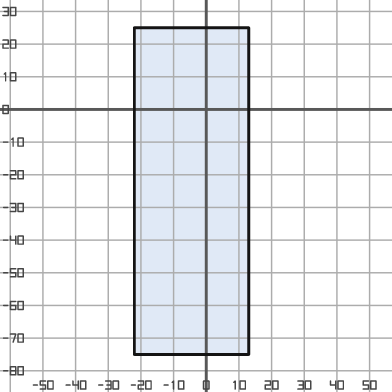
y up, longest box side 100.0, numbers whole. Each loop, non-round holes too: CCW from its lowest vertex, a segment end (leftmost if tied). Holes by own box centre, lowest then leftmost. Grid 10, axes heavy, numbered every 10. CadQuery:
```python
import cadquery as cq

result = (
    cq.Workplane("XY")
    .moveTo(-22.0, -75.0)
    .lineTo(13.0, -75.0)
    .lineTo(13.0, 25.0)
    .lineTo(-22.0, 25.0)
    .close()
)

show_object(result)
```